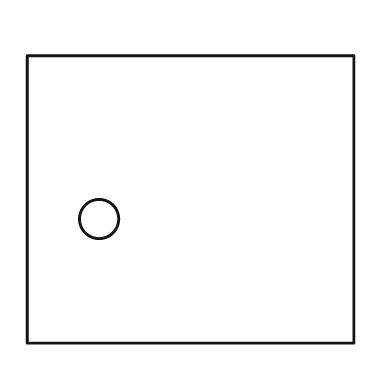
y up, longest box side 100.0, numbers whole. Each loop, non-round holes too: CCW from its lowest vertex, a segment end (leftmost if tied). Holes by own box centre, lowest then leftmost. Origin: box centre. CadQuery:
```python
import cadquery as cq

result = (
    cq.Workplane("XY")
    .moveTo(-50.0, -44.0)
    .lineTo(50.0, -44.0)
    .lineTo(50.0, 44.0)
    .lineTo(-50.0, 44.0)
    .close()
    .moveTo(-28.0, -6.0)
    .circle(6.0)
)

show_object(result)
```